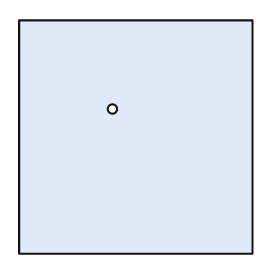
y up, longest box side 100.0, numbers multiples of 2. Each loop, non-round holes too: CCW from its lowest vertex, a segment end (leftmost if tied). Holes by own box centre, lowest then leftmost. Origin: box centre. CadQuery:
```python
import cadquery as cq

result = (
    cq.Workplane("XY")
    .moveTo(-50.0, -50.0)
    .lineTo(50.0, -50.0)
    .lineTo(50.0, 50.0)
    .lineTo(-50.0, 50.0)
    .close()
    .moveTo(-10.0, 12.0)
    .circle(2.0)
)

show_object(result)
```